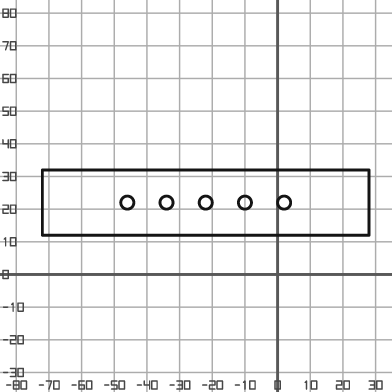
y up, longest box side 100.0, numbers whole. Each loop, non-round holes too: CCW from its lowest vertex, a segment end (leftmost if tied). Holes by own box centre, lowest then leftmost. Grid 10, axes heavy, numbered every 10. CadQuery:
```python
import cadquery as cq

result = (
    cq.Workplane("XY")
    .moveTo(-72.0, 12.0)
    .lineTo(28.0, 12.0)
    .lineTo(28.0, 32.0)
    .lineTo(-72.0, 32.0)
    .close()
    .moveTo(-46.0, 22.0)
    .circle(2.0)
    .moveTo(-34.0, 22.0)
    .circle(2.0)
    .moveTo(-22.0, 22.0)
    .circle(2.0)
    .moveTo(-10.0, 22.0)
    .circle(2.0)
    .moveTo(2.0, 22.0)
    .circle(2.0)
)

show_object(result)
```